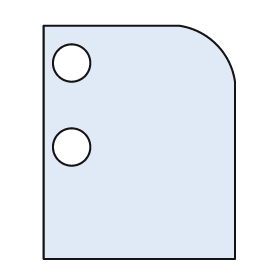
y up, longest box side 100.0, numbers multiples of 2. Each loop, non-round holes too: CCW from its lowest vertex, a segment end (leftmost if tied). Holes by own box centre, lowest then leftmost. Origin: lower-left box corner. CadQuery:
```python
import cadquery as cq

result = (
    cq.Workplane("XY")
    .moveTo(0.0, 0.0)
    .lineTo(82.0, 0.0)
    .lineTo(82.0, 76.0)
    .threePointArc((74.0, 92.0), (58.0, 100.0))
    .lineTo(0.0, 100.0)
    .close()
    .moveTo(12.0, 48.0)
    .circle(8.0)
    .moveTo(12.0, 84.0)
    .circle(8.0)
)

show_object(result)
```